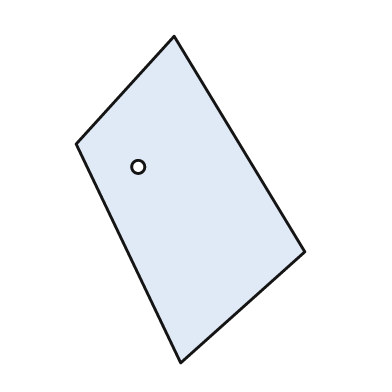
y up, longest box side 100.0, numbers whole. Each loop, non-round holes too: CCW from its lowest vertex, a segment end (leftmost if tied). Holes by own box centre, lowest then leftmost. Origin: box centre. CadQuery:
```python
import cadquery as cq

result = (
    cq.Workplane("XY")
    .moveTo(-3.0, -50.0)
    .lineTo(35.0, -16.0)
    .lineTo(-5.0, 50.0)
    .lineTo(-35.0, 17.0)
    .close()
    .moveTo(-16.0, 10.0)
    .circle(2.0)
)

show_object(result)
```